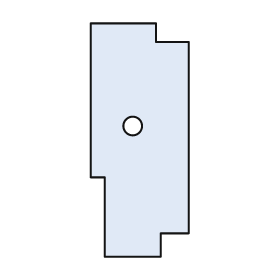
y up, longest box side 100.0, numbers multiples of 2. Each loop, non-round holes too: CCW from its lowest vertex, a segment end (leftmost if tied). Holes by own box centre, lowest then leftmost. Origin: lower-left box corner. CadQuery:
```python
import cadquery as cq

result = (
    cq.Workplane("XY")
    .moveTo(6.0, 0.0)
    .lineTo(30.0, 0.0)
    .lineTo(30.0, 10.0)
    .lineTo(42.0, 10.0)
    .lineTo(42.0, 92.0)
    .lineTo(28.0, 92.0)
    .lineTo(28.0, 100.0)
    .lineTo(0.0, 100.0)
    .lineTo(0.0, 34.0)
    .lineTo(6.0, 34.0)
    .close()
    .moveTo(18.0, 56.0)
    .circle(4.0)
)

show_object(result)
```